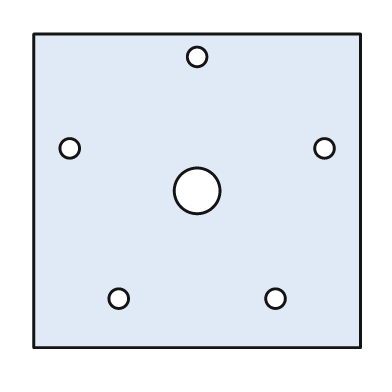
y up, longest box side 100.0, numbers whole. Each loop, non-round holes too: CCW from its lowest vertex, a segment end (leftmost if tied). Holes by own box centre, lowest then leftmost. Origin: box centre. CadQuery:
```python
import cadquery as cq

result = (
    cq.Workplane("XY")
    .moveTo(-50.0, -48.0)
    .lineTo(50.0, -48.0)
    .lineTo(50.0, 48.0)
    .lineTo(-50.0, 48.0)
    .close()
    .moveTo(-24.0, -33.0)
    .circle(3.0)
    .moveTo(24.0, -33.0)
    .circle(3.0)
    .moveTo(0.0, 0.0)
    .circle(7.0)
    .moveTo(-39.0, 13.0)
    .circle(3.0)
    .moveTo(39.0, 13.0)
    .circle(3.0)
    .moveTo(0.0, 41.0)
    .circle(3.0)
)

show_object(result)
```